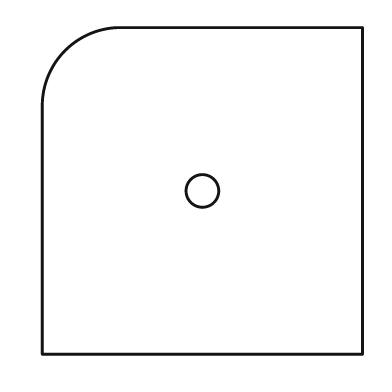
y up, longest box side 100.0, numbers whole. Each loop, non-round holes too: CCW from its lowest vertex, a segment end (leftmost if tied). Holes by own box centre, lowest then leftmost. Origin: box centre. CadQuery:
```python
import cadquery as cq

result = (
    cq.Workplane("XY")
    .moveTo(-49.0, -50.0)
    .lineTo(49.0, -50.0)
    .lineTo(49.0, 50.0)
    .lineTo(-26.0, 50.0)
    .threePointArc((-42.0, 43.0), (-49.0, 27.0))
    .close()
    .moveTo(0.0, 0.0)
    .circle(5.0)
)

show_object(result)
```